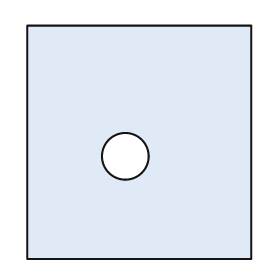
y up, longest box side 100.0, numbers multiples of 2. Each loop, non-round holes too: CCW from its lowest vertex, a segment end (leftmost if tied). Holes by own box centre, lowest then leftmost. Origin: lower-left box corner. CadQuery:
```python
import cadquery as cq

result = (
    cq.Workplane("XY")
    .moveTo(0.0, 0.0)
    .lineTo(96.0, 0.0)
    .lineTo(96.0, 100.0)
    .lineTo(0.0, 100.0)
    .close()
    .moveTo(42.0, 44.0)
    .circle(10.0)
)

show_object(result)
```